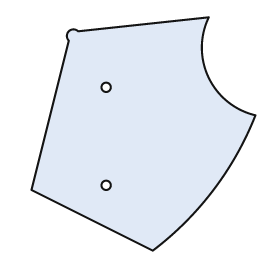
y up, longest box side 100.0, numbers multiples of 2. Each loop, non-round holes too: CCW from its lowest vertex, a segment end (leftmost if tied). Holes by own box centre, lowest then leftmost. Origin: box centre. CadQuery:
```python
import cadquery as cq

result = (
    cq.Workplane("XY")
    .moveTo(4.0, -50.0)
    .threePointArc((30.0, -24.0), (48.0, 8.0))
    .threePointArc((28.0, 24.0), (28.0, 50.0))
    .lineTo(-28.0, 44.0)
    .threePointArc((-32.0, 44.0), (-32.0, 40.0))
    .lineTo(-48.0, -24.0)
    .close()
    .moveTo(-16.0, -22.0)
    .circle(2.0)
    .moveTo(-16.0, 20.0)
    .circle(2.0)
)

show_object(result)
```